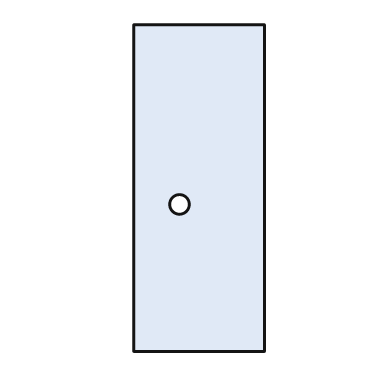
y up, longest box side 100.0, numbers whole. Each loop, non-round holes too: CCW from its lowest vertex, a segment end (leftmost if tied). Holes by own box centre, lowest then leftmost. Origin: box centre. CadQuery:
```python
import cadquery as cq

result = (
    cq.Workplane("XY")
    .moveTo(-20.0, -50.0)
    .lineTo(20.0, -50.0)
    .lineTo(20.0, 50.0)
    .lineTo(-20.0, 50.0)
    .close()
    .moveTo(-6.0, -5.0)
    .circle(3.0)
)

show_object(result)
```